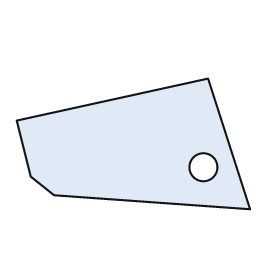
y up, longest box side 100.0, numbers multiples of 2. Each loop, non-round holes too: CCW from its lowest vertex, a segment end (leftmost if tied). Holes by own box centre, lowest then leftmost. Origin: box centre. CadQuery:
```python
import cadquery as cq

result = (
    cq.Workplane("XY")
    .moveTo(50.0, -28.0)
    .lineTo(32.0, 28.0)
    .lineTo(-50.0, 10.0)
    .lineTo(-44.0, -14.0)
    .lineTo(-34.0, -22.0)
    .close()
    .moveTo(30.0, -10.0)
    .circle(6.0)
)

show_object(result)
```